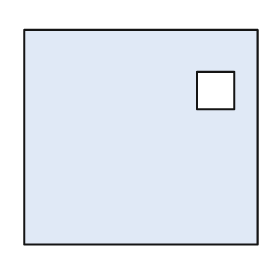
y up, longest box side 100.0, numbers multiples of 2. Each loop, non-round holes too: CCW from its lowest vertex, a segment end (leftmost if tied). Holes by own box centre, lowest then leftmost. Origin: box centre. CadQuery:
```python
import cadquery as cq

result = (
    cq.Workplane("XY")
    .moveTo(-50.0, -46.0)
    .lineTo(50.0, -46.0)
    .lineTo(50.0, 46.0)
    .lineTo(-50.0, 46.0)
    .close()
    .moveTo(24.0, 12.0)
    .lineTo(40.0, 12.0)
    .lineTo(40.0, 28.0)
    .lineTo(24.0, 28.0)
    .close()
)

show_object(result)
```